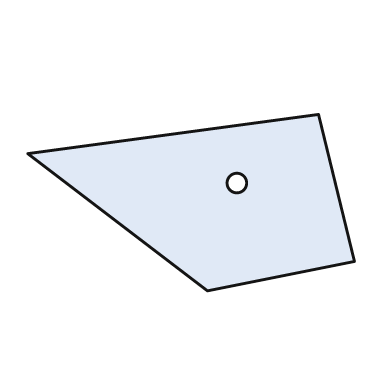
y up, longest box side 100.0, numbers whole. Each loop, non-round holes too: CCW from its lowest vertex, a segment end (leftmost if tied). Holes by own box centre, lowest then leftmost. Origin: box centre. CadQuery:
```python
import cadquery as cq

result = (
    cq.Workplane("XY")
    .moveTo(5.0, -27.0)
    .lineTo(50.0, -18.0)
    .lineTo(39.0, 27.0)
    .lineTo(-50.0, 15.0)
    .close()
    .moveTo(14.0, 6.0)
    .circle(3.0)
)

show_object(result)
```